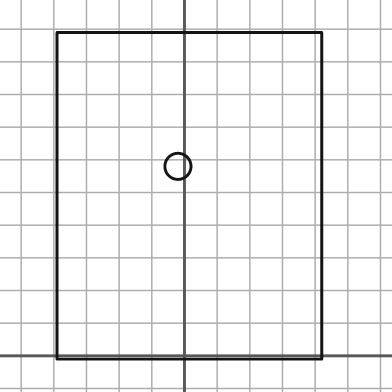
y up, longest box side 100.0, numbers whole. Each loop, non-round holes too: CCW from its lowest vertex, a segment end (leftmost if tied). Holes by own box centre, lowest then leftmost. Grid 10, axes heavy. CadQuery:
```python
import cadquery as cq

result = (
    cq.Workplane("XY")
    .moveTo(-39.0, -1.0)
    .lineTo(42.0, -1.0)
    .lineTo(42.0, 99.0)
    .lineTo(-39.0, 99.0)
    .close()
    .moveTo(-2.0, 58.0)
    .circle(4.0)
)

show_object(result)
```